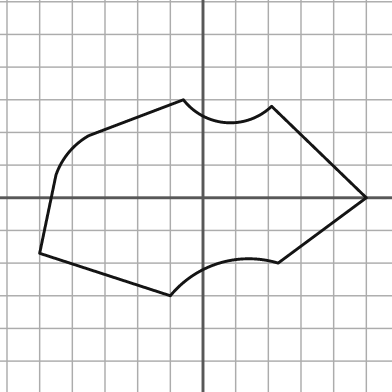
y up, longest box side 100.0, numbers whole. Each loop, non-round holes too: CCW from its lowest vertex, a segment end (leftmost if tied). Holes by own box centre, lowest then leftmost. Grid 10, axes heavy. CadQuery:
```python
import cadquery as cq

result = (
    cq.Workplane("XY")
    .moveTo(-10.0, -30.0)
    .threePointArc((5.0, -20.0), (23.0, -20.0))
    .lineTo(50.0, 0.0)
    .lineTo(21.0, 28.0)
    .threePointArc((7.0, 23.0), (-6.0, 30.0))
    .lineTo(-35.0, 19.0)
    .threePointArc((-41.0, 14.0), (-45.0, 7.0))
    .lineTo(-50.0, -17.0)
    .close()
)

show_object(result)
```